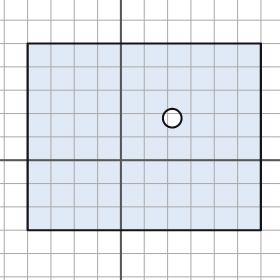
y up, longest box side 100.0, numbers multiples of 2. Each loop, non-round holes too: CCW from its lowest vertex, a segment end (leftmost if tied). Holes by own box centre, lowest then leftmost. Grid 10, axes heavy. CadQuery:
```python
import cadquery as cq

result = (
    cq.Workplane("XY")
    .moveTo(-40.0, -30.0)
    .lineTo(60.0, -30.0)
    .lineTo(60.0, 50.0)
    .lineTo(-40.0, 50.0)
    .close()
    .moveTo(22.0, 18.0)
    .circle(4.0)
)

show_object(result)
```